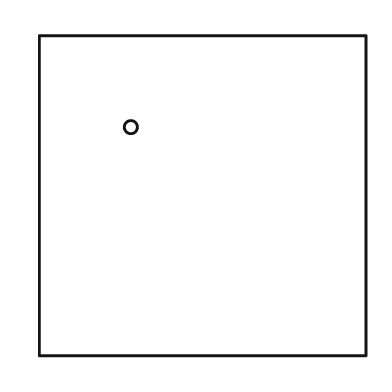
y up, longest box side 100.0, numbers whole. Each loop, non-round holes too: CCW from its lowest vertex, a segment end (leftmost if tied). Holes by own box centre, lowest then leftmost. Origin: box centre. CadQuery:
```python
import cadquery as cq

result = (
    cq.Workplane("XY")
    .moveTo(-50.0, -49.0)
    .lineTo(50.0, -49.0)
    .lineTo(50.0, 49.0)
    .lineTo(-50.0, 49.0)
    .close()
    .moveTo(-22.0, 21.0)
    .circle(2.0)
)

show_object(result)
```